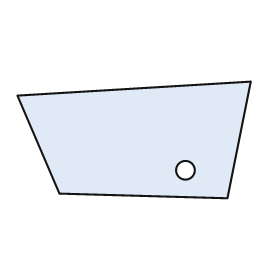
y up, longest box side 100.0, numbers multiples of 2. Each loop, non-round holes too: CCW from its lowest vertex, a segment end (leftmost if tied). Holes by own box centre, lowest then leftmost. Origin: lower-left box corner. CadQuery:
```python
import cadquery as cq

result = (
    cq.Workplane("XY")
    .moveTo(90.0, 0.0)
    .lineTo(100.0, 50.0)
    .lineTo(0.0, 44.0)
    .lineTo(18.0, 2.0)
    .close()
    .moveTo(72.0, 12.0)
    .circle(4.0)
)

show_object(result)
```